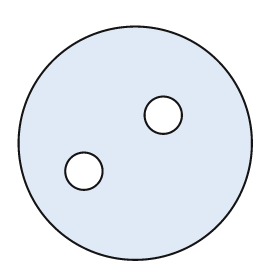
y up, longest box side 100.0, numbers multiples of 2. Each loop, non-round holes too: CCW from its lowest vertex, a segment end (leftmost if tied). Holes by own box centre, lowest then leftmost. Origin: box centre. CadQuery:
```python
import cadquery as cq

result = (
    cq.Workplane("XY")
    .moveTo(0.0, 0.0)
    .circle(50.0)
    .moveTo(-22.0, -12.0)
    .circle(8.0)
    .moveTo(12.0, 12.0)
    .circle(8.0)
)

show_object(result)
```